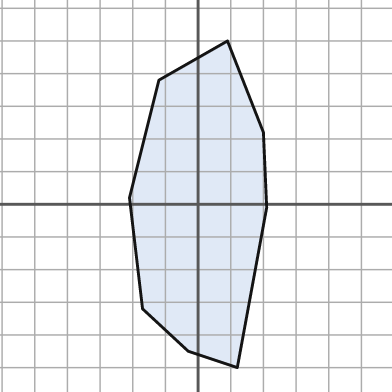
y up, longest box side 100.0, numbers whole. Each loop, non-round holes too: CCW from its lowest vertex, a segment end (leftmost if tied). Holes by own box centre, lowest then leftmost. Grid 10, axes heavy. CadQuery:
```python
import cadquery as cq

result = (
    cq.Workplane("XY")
    .moveTo(12.0, -50.0)
    .lineTo(21.0, -1.0)
    .lineTo(20.0, 22.0)
    .lineTo(9.0, 50.0)
    .lineTo(-12.0, 38.0)
    .lineTo(-21.0, 2.0)
    .lineTo(-17.0, -32.0)
    .lineTo(-3.0, -45.0)
    .close()
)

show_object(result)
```